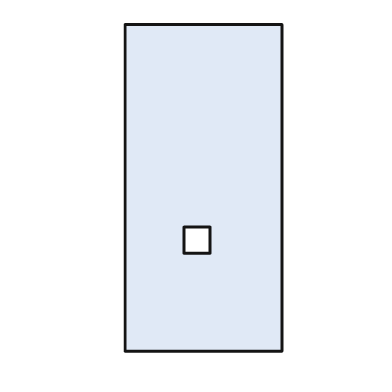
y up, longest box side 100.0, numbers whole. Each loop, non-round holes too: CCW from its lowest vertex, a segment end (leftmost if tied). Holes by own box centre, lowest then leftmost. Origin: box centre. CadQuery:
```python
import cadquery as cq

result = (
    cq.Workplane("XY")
    .moveTo(-24.0, -50.0)
    .lineTo(24.0, -50.0)
    .lineTo(24.0, 50.0)
    .lineTo(-24.0, 50.0)
    .close()
    .moveTo(-6.0, -20.0)
    .lineTo(2.0, -20.0)
    .lineTo(2.0, -12.0)
    .lineTo(-6.0, -12.0)
    .close()
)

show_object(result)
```